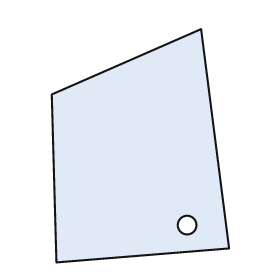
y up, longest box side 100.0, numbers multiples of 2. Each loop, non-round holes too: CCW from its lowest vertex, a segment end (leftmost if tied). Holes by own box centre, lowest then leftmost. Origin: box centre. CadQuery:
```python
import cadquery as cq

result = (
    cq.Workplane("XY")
    .moveTo(-36.0, -50.0)
    .lineTo(38.0, -44.0)
    .lineTo(26.0, 50.0)
    .lineTo(-38.0, 22.0)
    .close()
    .moveTo(20.0, -34.0)
    .circle(4.0)
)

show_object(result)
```